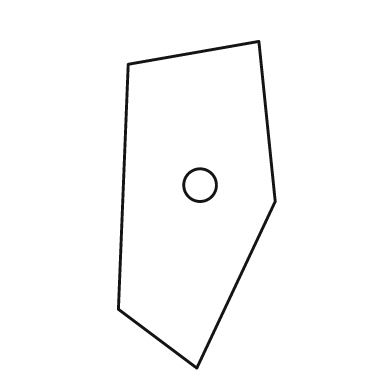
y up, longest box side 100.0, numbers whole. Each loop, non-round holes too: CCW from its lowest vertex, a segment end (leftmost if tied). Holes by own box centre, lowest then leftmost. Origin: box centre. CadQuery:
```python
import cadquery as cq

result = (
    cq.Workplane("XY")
    .moveTo(0.0, -50.0)
    .lineTo(24.0, 1.0)
    .lineTo(19.0, 50.0)
    .lineTo(-21.0, 43.0)
    .lineTo(-24.0, -32.0)
    .close()
    .moveTo(1.0, 6.0)
    .circle(5.0)
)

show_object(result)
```